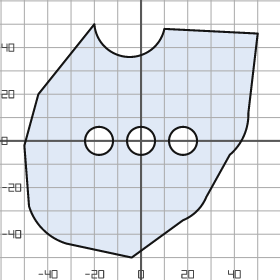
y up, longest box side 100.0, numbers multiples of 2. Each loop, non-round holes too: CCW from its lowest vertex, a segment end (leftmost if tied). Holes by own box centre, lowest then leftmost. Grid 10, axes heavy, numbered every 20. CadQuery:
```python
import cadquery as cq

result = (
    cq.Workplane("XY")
    .moveTo(-4.0, -50.0)
    .lineTo(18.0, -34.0)
    .threePointArc((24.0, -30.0), (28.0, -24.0))
    .lineTo(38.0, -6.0)
    .threePointArc((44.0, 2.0), (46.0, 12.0))
    .lineTo(50.0, 46.0)
    .lineTo(10.0, 48.0)
    .threePointArc((-6.0, 36.0), (-20.0, 50.0))
    .lineTo(-44.0, 20.0)
    .lineTo(-50.0, -2.0)
    .lineTo(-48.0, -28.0)
    .threePointArc((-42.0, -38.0), (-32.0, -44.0))
    .close()
    .moveTo(-18.0, 0.0)
    .circle(6.0)
    .moveTo(0.0, 0.0)
    .circle(6.0)
    .moveTo(18.0, 0.0)
    .circle(6.0)
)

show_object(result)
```